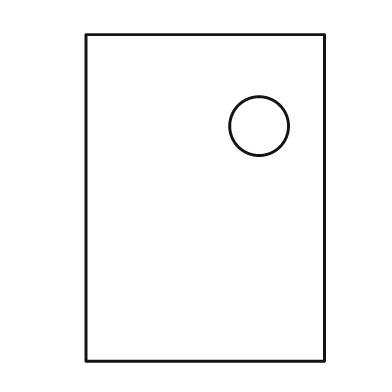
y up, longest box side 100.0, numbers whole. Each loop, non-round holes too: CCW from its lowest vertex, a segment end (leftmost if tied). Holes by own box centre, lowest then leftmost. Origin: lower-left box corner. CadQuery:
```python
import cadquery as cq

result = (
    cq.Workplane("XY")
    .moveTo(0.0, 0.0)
    .lineTo(73.0, 0.0)
    .lineTo(73.0, 100.0)
    .lineTo(0.0, 100.0)
    .close()
    .moveTo(53.0, 72.0)
    .circle(9.0)
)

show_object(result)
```